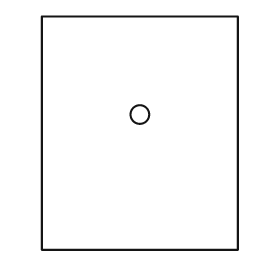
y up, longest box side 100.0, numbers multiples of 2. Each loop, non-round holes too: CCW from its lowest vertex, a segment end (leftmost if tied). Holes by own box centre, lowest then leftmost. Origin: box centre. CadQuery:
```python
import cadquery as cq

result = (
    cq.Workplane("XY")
    .moveTo(-42.0, -50.0)
    .lineTo(42.0, -50.0)
    .lineTo(42.0, 50.0)
    .lineTo(-42.0, 50.0)
    .close()
    .moveTo(0.0, 8.0)
    .circle(4.0)
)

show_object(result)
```